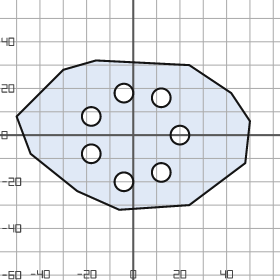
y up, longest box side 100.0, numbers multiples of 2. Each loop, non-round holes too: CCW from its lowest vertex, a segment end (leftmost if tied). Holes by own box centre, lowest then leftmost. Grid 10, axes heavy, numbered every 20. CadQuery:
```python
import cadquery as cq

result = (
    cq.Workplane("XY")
    .moveTo(-6.0, -32.0)
    .lineTo(24.0, -30.0)
    .lineTo(48.0, -12.0)
    .lineTo(50.0, 6.0)
    .lineTo(42.0, 18.0)
    .lineTo(24.0, 30.0)
    .lineTo(-16.0, 32.0)
    .lineTo(-30.0, 28.0)
    .lineTo(-50.0, 8.0)
    .lineTo(-44.0, -8.0)
    .lineTo(-24.0, -24.0)
    .close()
    .moveTo(-4.0, -20.0)
    .circle(4.0)
    .moveTo(12.0, -16.0)
    .circle(4.0)
    .moveTo(-18.0, -8.0)
    .circle(4.0)
    .moveTo(20.0, 0.0)
    .circle(4.0)
    .moveTo(-18.0, 8.0)
    .circle(4.0)
    .moveTo(12.0, 16.0)
    .circle(4.0)
    .moveTo(-4.0, 18.0)
    .circle(4.0)
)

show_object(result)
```